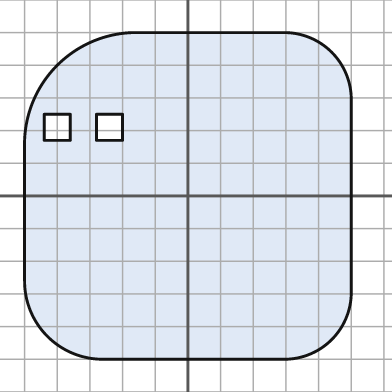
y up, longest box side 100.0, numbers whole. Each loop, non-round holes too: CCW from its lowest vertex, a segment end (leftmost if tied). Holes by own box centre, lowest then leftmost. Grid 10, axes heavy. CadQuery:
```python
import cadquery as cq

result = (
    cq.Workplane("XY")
    .moveTo(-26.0, -50.0)
    .lineTo(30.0, -50.0)
    .threePointArc((44.0, -44.0), (50.0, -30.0))
    .lineTo(50.0, 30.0)
    .threePointArc((44.0, 44.0), (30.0, 50.0))
    .lineTo(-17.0, 50.0)
    .threePointArc((-40.0, 40.0), (-50.0, 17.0))
    .lineTo(-50.0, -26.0)
    .threePointArc((-43.0, -43.0), (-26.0, -50.0))
    .close()
    .moveTo(-44.0, 17.0)
    .lineTo(-36.0, 17.0)
    .lineTo(-36.0, 25.0)
    .lineTo(-44.0, 25.0)
    .close()
    .moveTo(-28.0, 17.0)
    .lineTo(-20.0, 17.0)
    .lineTo(-20.0, 25.0)
    .lineTo(-28.0, 25.0)
    .close()
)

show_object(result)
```